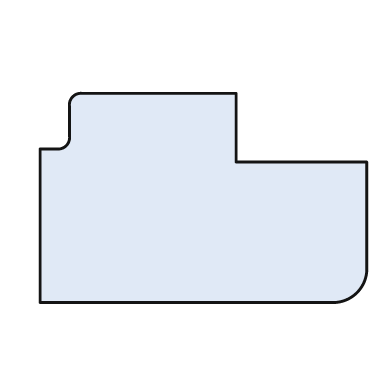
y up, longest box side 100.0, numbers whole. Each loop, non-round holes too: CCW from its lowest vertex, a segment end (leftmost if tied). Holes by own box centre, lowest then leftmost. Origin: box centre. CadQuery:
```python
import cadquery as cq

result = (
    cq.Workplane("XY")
    .moveTo(-50.0, -32.0)
    .lineTo(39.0, -32.0)
    .threePointArc((47.0, -29.0), (50.0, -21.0))
    .lineTo(50.0, 11.0)
    .lineTo(10.0, 11.0)
    .lineTo(10.0, 32.0)
    .lineTo(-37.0, 32.0)
    .threePointArc((-40.0, 31.0), (-41.0, 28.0))
    .lineTo(-41.0, 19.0)
    .threePointArc((-42.0, 16.0), (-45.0, 15.0))
    .lineTo(-50.0, 15.0)
    .close()
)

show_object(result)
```